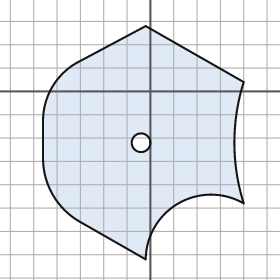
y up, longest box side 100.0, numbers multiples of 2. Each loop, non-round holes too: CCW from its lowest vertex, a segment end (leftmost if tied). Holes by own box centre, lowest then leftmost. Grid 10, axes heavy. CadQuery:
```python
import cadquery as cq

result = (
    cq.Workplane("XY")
    .moveTo(-2.0, -72.0)
    .threePointArc((12.0, -48.0), (40.0, -48.0))
    .threePointArc((36.0, -22.0), (40.0, 4.0))
    .lineTo(-2.0, 28.0)
    .lineTo(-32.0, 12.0)
    .threePointArc((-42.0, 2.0), (-46.0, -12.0))
    .lineTo(-46.0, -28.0)
    .threePointArc((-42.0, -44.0), (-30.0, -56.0))
    .close()
    .moveTo(-4.0, -22.0)
    .circle(4.0)
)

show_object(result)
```